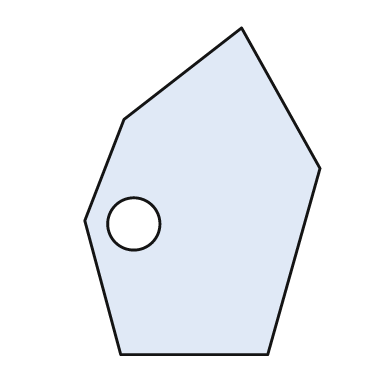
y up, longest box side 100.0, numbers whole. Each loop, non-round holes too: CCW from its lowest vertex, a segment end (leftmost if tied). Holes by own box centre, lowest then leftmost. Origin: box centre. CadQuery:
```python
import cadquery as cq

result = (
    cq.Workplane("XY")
    .moveTo(-25.0, -50.0)
    .lineTo(20.0, -50.0)
    .lineTo(36.0, 7.0)
    .lineTo(12.0, 50.0)
    .lineTo(-24.0, 22.0)
    .lineTo(-36.0, -9.0)
    .close()
    .moveTo(-21.0, -10.0)
    .circle(8.0)
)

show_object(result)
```